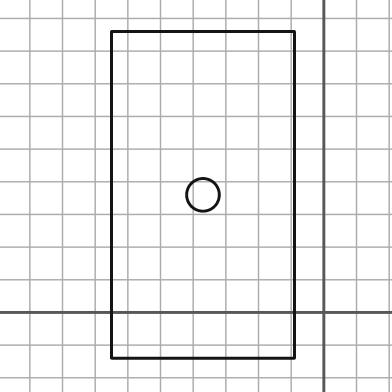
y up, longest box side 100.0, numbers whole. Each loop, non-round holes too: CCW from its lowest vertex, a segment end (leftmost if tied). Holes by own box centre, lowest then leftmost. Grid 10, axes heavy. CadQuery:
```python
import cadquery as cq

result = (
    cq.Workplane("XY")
    .moveTo(-65.0, -14.0)
    .lineTo(-9.0, -14.0)
    .lineTo(-9.0, 86.0)
    .lineTo(-65.0, 86.0)
    .close()
    .moveTo(-37.0, 36.0)
    .circle(5.0)
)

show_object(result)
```